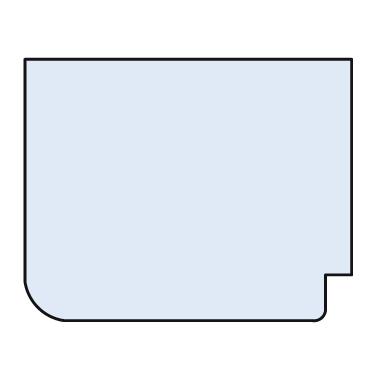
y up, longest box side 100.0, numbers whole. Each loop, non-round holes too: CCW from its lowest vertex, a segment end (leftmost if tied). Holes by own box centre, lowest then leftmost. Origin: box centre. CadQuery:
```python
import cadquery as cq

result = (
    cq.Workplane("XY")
    .moveTo(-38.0, -40.0)
    .lineTo(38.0, -40.0)
    .threePointArc((41.0, -39.0), (42.0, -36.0))
    .lineTo(42.0, -26.0)
    .lineTo(50.0, -26.0)
    .lineTo(50.0, 40.0)
    .lineTo(-50.0, 40.0)
    .lineTo(-50.0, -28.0)
    .threePointArc((-46.0, -36.0), (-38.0, -40.0))
    .close()
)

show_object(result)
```